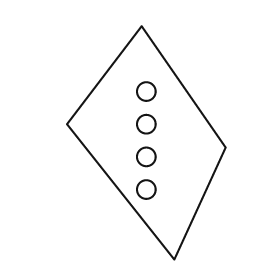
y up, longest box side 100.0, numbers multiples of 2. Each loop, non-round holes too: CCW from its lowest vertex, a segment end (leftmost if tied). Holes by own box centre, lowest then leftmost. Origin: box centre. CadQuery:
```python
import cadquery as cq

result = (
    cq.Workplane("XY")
    .moveTo(12.0, -50.0)
    .lineTo(34.0, -2.0)
    .lineTo(-2.0, 50.0)
    .lineTo(-34.0, 8.0)
    .close()
    .moveTo(0.0, -20.0)
    .circle(4.0)
    .moveTo(0.0, -6.0)
    .circle(4.0)
    .moveTo(0.0, 8.0)
    .circle(4.0)
    .moveTo(0.0, 22.0)
    .circle(4.0)
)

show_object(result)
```